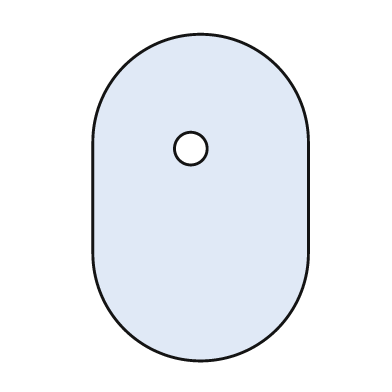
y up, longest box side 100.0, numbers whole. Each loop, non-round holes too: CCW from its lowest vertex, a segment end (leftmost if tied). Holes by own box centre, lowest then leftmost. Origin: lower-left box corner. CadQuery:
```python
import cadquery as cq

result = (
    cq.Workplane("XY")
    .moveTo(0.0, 33.0)
    .threePointArc((33.0, 0.0), (66.0, 33.0))
    .lineTo(66.0, 67.0)
    .threePointArc((33.0, 100.0), (0.0, 67.0))
    .close()
    .moveTo(30.0, 65.0)
    .circle(5.0)
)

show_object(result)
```